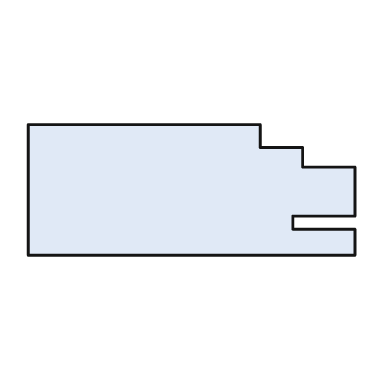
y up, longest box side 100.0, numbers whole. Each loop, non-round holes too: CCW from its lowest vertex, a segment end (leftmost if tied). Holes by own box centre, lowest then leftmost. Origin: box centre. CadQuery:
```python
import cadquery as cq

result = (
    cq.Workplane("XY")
    .moveTo(-50.0, -20.0)
    .lineTo(50.0, -20.0)
    .lineTo(50.0, -12.0)
    .lineTo(31.0, -12.0)
    .lineTo(31.0, -8.0)
    .lineTo(50.0, -8.0)
    .lineTo(50.0, 7.0)
    .lineTo(34.0, 7.0)
    .lineTo(34.0, 13.0)
    .lineTo(21.0, 13.0)
    .lineTo(21.0, 20.0)
    .lineTo(-50.0, 20.0)
    .close()
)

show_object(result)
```